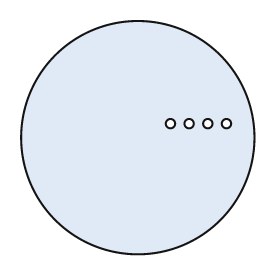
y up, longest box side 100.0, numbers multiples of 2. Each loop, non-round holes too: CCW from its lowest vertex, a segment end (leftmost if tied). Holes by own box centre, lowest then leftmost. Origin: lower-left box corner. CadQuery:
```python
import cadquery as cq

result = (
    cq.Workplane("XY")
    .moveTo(50.0, 50.0)
    .circle(50.0)
    .moveTo(64.0, 56.0)
    .circle(2.0)
    .moveTo(72.0, 56.0)
    .circle(2.0)
    .moveTo(80.0, 56.0)
    .circle(2.0)
    .moveTo(88.0, 56.0)
    .circle(2.0)
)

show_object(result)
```